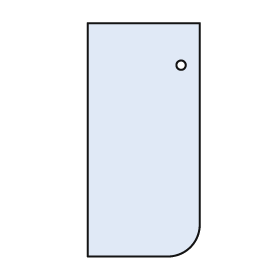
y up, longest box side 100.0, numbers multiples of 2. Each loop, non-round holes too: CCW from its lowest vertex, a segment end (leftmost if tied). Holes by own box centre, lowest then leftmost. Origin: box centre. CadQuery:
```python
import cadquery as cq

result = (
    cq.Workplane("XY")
    .moveTo(-24.0, -50.0)
    .lineTo(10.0, -50.0)
    .threePointArc((20.0, -46.0), (24.0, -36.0))
    .lineTo(24.0, 50.0)
    .lineTo(-24.0, 50.0)
    .close()
    .moveTo(16.0, 32.0)
    .circle(2.0)
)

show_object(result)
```